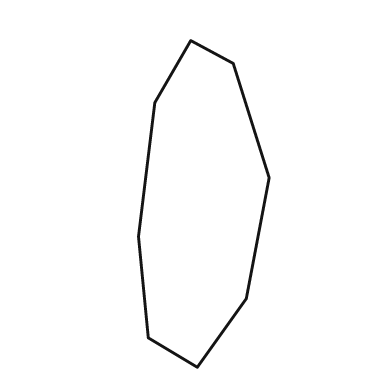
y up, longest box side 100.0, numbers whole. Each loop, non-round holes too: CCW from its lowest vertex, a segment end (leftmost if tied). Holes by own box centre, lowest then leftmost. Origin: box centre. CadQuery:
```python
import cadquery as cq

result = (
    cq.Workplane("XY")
    .moveTo(-2.0, -50.0)
    .lineTo(13.0, -29.0)
    .lineTo(20.0, 8.0)
    .lineTo(9.0, 43.0)
    .lineTo(-4.0, 50.0)
    .lineTo(-15.0, 31.0)
    .lineTo(-20.0, -10.0)
    .lineTo(-17.0, -41.0)
    .close()
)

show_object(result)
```